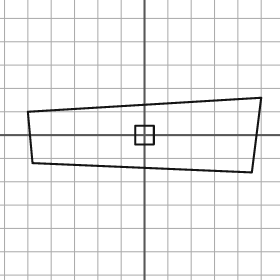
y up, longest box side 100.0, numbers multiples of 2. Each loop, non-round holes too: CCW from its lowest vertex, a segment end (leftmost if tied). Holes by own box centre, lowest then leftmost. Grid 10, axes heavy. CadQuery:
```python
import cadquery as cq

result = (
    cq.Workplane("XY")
    .moveTo(46.0, -16.0)
    .lineTo(50.0, 16.0)
    .lineTo(-50.0, 10.0)
    .lineTo(-48.0, -12.0)
    .close()
    .moveTo(-4.0, -4.0)
    .lineTo(4.0, -4.0)
    .lineTo(4.0, 4.0)
    .lineTo(-4.0, 4.0)
    .close()
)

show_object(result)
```